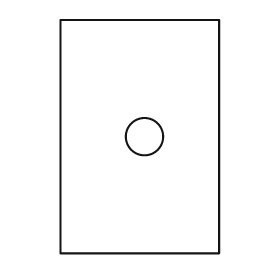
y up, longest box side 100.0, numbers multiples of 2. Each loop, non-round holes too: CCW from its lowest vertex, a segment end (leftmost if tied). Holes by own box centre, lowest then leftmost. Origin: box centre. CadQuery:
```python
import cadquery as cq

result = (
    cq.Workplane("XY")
    .moveTo(-34.0, -50.0)
    .lineTo(34.0, -50.0)
    .lineTo(34.0, 50.0)
    .lineTo(-34.0, 50.0)
    .close()
    .moveTo(2.0, 0.0)
    .circle(8.0)
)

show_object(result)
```